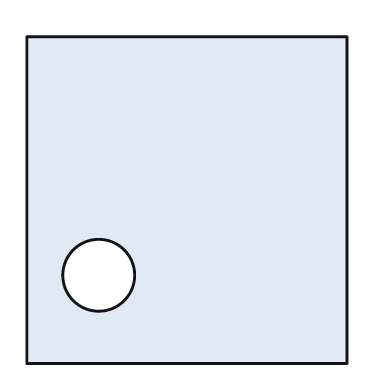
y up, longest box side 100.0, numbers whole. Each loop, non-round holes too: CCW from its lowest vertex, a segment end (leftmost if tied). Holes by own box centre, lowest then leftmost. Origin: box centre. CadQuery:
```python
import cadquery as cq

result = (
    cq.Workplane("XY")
    .moveTo(-49.0, -50.0)
    .lineTo(49.0, -50.0)
    .lineTo(49.0, 50.0)
    .lineTo(-49.0, 50.0)
    .close()
    .moveTo(-27.0, -23.0)
    .circle(11.0)
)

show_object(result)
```